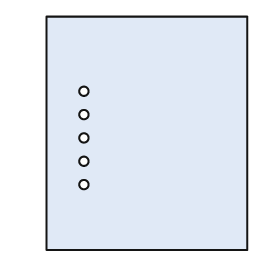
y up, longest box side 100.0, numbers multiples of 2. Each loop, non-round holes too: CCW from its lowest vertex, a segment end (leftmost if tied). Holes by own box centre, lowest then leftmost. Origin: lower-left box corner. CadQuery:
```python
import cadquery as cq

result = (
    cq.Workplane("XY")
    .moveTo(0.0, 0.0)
    .lineTo(86.0, 0.0)
    .lineTo(86.0, 100.0)
    .lineTo(0.0, 100.0)
    .close()
    .moveTo(16.0, 28.0)
    .circle(2.0)
    .moveTo(16.0, 38.0)
    .circle(2.0)
    .moveTo(16.0, 48.0)
    .circle(2.0)
    .moveTo(16.0, 58.0)
    .circle(2.0)
    .moveTo(16.0, 68.0)
    .circle(2.0)
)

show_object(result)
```